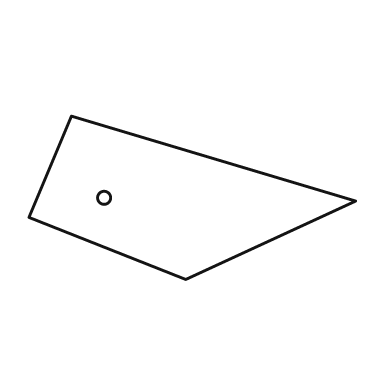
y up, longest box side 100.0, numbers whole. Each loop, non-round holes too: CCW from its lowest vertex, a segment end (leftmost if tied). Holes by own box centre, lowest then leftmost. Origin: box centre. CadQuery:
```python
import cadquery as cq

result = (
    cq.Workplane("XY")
    .moveTo(-2.0, -25.0)
    .lineTo(50.0, -1.0)
    .lineTo(-37.0, 25.0)
    .lineTo(-50.0, -6.0)
    .close()
    .moveTo(-27.0, 0.0)
    .circle(2.0)
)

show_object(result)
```